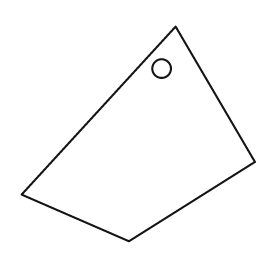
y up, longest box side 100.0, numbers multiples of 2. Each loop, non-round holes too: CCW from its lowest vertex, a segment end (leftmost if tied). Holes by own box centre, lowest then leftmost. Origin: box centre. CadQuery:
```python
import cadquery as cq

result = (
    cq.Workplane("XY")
    .moveTo(-4.0, -46.0)
    .lineTo(50.0, -12.0)
    .lineTo(16.0, 46.0)
    .lineTo(-50.0, -26.0)
    .close()
    .moveTo(10.0, 28.0)
    .circle(4.0)
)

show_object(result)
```